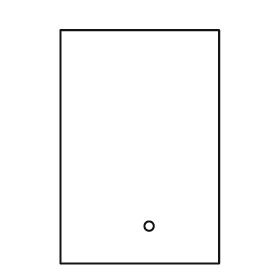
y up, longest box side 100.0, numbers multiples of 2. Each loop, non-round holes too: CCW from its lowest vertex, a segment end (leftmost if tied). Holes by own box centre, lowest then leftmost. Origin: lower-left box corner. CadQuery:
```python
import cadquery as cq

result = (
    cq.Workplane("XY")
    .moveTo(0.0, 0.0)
    .lineTo(68.0, 0.0)
    .lineTo(68.0, 100.0)
    .lineTo(0.0, 100.0)
    .close()
    .moveTo(38.0, 16.0)
    .circle(2.0)
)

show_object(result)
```